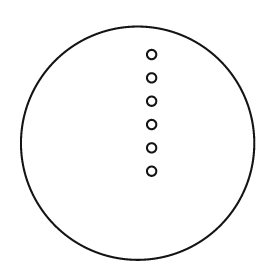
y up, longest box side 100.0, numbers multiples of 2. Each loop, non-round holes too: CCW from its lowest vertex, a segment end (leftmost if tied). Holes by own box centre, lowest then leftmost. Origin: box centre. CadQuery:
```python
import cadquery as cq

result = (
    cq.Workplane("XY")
    .moveTo(0.0, 0.0)
    .circle(50.0)
    .moveTo(6.0, -12.0)
    .circle(2.0)
    .moveTo(6.0, -2.0)
    .circle(2.0)
    .moveTo(6.0, 8.0)
    .circle(2.0)
    .moveTo(6.0, 18.0)
    .circle(2.0)
    .moveTo(6.0, 28.0)
    .circle(2.0)
    .moveTo(6.0, 38.0)
    .circle(2.0)
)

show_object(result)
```